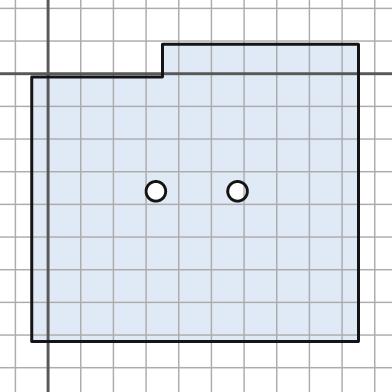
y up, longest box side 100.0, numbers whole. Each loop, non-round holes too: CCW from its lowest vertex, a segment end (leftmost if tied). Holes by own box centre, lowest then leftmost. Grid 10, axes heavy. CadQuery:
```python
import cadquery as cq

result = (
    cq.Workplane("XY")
    .moveTo(-5.0, -82.0)
    .lineTo(95.0, -82.0)
    .lineTo(95.0, 9.0)
    .lineTo(35.0, 9.0)
    .lineTo(35.0, -1.0)
    .lineTo(-5.0, -1.0)
    .close()
    .moveTo(33.0, -36.0)
    .circle(3.0)
    .moveTo(58.0, -36.0)
    .circle(3.0)
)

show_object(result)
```